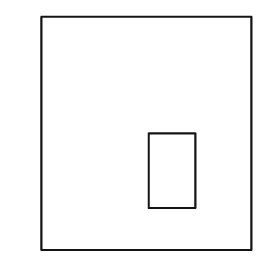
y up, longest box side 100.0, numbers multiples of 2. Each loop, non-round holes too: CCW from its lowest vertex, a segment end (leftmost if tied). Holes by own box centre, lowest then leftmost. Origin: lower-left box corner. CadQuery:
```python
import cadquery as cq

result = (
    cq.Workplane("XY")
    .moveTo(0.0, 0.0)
    .lineTo(90.0, 0.0)
    .lineTo(90.0, 100.0)
    .lineTo(0.0, 100.0)
    .close()
    .moveTo(46.0, 18.0)
    .lineTo(66.0, 18.0)
    .lineTo(66.0, 50.0)
    .lineTo(46.0, 50.0)
    .close()
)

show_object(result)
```